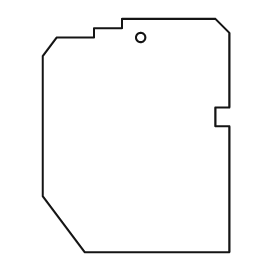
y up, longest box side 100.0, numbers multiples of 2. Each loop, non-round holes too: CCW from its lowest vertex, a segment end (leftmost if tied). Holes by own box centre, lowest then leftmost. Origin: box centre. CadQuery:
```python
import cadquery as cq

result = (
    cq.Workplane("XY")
    .moveTo(-22.0, -50.0)
    .lineTo(40.0, -50.0)
    .lineTo(40.0, 4.0)
    .lineTo(34.0, 4.0)
    .lineTo(34.0, 12.0)
    .lineTo(40.0, 12.0)
    .lineTo(40.0, 44.0)
    .lineTo(34.0, 50.0)
    .lineTo(-6.0, 50.0)
    .lineTo(-6.0, 46.0)
    .lineTo(-18.0, 46.0)
    .lineTo(-18.0, 42.0)
    .lineTo(-34.0, 42.0)
    .lineTo(-40.0, 34.0)
    .lineTo(-40.0, -26.0)
    .close()
    .moveTo(2.0, 42.0)
    .circle(2.0)
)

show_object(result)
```